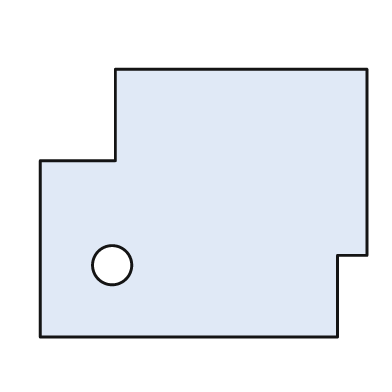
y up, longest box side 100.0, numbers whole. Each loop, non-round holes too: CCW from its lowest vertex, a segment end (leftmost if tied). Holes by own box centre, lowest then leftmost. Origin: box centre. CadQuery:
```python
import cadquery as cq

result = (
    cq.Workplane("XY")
    .moveTo(-50.0, -41.0)
    .lineTo(41.0, -41.0)
    .lineTo(41.0, -16.0)
    .lineTo(50.0, -16.0)
    .lineTo(50.0, 41.0)
    .lineTo(-27.0, 41.0)
    .lineTo(-27.0, 13.0)
    .lineTo(-50.0, 13.0)
    .close()
    .moveTo(-28.0, -19.0)
    .circle(6.0)
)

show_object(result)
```